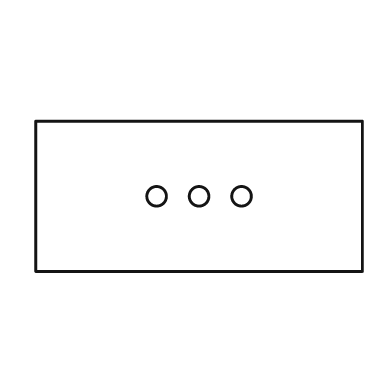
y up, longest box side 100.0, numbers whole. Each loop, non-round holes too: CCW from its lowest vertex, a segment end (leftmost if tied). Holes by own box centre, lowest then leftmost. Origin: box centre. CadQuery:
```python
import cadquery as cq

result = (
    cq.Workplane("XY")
    .moveTo(-50.0, -23.0)
    .lineTo(50.0, -23.0)
    .lineTo(50.0, 23.0)
    .lineTo(-50.0, 23.0)
    .close()
    .moveTo(-13.0, 0.0)
    .circle(3.0)
    .moveTo(0.0, 0.0)
    .circle(3.0)
    .moveTo(13.0, 0.0)
    .circle(3.0)
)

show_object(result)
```